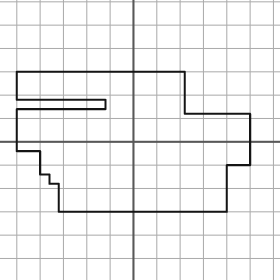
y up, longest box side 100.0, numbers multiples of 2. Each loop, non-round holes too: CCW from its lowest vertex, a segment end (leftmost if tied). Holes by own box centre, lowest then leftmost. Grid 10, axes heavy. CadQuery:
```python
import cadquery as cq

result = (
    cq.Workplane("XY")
    .moveTo(-32.0, -30.0)
    .lineTo(40.0, -30.0)
    .lineTo(40.0, -10.0)
    .lineTo(50.0, -10.0)
    .lineTo(50.0, 12.0)
    .lineTo(22.0, 12.0)
    .lineTo(22.0, 30.0)
    .lineTo(-50.0, 30.0)
    .lineTo(-50.0, 18.0)
    .lineTo(-12.0, 18.0)
    .lineTo(-12.0, 14.0)
    .lineTo(-50.0, 14.0)
    .lineTo(-50.0, -4.0)
    .lineTo(-40.0, -4.0)
    .lineTo(-40.0, -14.0)
    .lineTo(-36.0, -14.0)
    .lineTo(-36.0, -18.0)
    .lineTo(-32.0, -18.0)
    .close()
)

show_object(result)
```